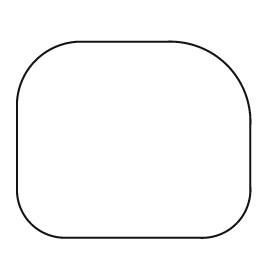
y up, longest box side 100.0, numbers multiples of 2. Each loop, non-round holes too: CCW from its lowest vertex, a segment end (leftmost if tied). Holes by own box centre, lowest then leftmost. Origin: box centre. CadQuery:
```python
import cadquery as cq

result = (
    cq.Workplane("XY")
    .moveTo(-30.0, -42.0)
    .lineTo(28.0, -42.0)
    .threePointArc((44.0, -36.0), (50.0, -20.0))
    .lineTo(50.0, 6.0)
    .threePointArc((40.0, 32.0), (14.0, 42.0))
    .lineTo(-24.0, 42.0)
    .threePointArc((-42.0, 34.0), (-50.0, 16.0))
    .lineTo(-50.0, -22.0)
    .threePointArc((-44.0, -36.0), (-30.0, -42.0))
    .close()
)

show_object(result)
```